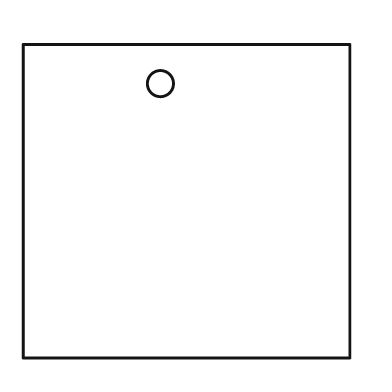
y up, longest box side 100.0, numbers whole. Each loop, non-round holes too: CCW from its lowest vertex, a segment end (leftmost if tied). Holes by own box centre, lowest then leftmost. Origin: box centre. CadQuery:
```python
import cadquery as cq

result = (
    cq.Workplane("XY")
    .moveTo(-50.0, -48.0)
    .lineTo(50.0, -48.0)
    .lineTo(50.0, 48.0)
    .lineTo(-50.0, 48.0)
    .close()
    .moveTo(-8.0, 36.0)
    .circle(4.0)
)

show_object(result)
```